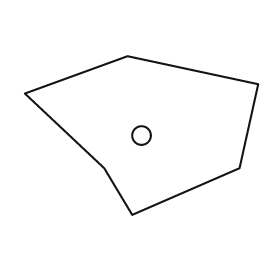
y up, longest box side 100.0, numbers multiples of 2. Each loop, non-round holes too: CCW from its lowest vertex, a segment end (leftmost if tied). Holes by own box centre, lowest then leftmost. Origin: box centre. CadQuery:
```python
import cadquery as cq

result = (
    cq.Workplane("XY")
    .moveTo(-4.0, -34.0)
    .lineTo(42.0, -14.0)
    .lineTo(50.0, 22.0)
    .lineTo(-6.0, 34.0)
    .lineTo(-50.0, 18.0)
    .lineTo(-16.0, -14.0)
    .close()
    .moveTo(0.0, 0.0)
    .circle(4.0)
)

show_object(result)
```